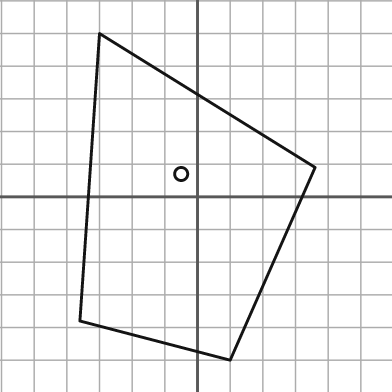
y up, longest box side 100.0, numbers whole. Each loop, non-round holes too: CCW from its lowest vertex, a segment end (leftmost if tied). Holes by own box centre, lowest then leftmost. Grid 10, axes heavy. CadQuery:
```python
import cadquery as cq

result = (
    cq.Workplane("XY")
    .moveTo(10.0, -50.0)
    .lineTo(36.0, 9.0)
    .lineTo(-30.0, 50.0)
    .lineTo(-36.0, -38.0)
    .close()
    .moveTo(-5.0, 7.0)
    .circle(2.0)
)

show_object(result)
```